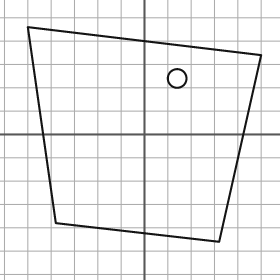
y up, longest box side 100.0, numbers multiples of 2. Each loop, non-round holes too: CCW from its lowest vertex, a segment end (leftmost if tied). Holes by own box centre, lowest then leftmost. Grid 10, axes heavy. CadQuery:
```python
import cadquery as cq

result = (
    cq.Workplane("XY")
    .moveTo(32.0, -46.0)
    .lineTo(50.0, 34.0)
    .lineTo(-50.0, 46.0)
    .lineTo(-38.0, -38.0)
    .close()
    .moveTo(14.0, 24.0)
    .circle(4.0)
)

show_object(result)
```